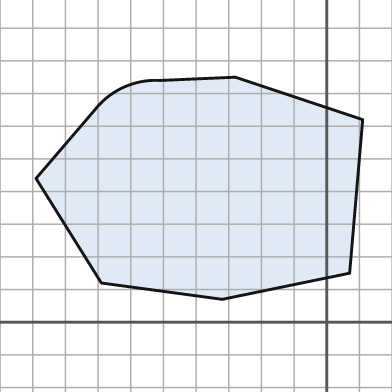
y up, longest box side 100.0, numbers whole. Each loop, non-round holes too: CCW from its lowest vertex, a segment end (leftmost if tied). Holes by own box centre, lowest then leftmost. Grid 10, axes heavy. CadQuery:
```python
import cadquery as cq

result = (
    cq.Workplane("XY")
    .moveTo(-32.0, 7.0)
    .lineTo(7.0, 15.0)
    .lineTo(11.0, 62.0)
    .lineTo(-28.0, 75.0)
    .lineTo(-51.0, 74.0)
    .threePointArc((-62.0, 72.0), (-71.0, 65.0))
    .lineTo(-89.0, 44.0)
    .lineTo(-69.0, 12.0)
    .close()
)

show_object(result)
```